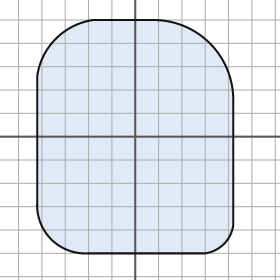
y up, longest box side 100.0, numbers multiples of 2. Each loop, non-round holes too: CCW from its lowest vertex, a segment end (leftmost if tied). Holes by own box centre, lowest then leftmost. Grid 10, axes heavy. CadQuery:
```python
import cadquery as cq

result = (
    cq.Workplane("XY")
    .moveTo(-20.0, -50.0)
    .lineTo(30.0, -50.0)
    .threePointArc((38.0, -46.0), (42.0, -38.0))
    .lineTo(42.0, 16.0)
    .threePointArc((32.0, 40.0), (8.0, 50.0))
    .lineTo(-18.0, 50.0)
    .threePointArc((-34.0, 42.0), (-42.0, 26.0))
    .lineTo(-42.0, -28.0)
    .threePointArc((-36.0, -44.0), (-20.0, -50.0))
    .close()
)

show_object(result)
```